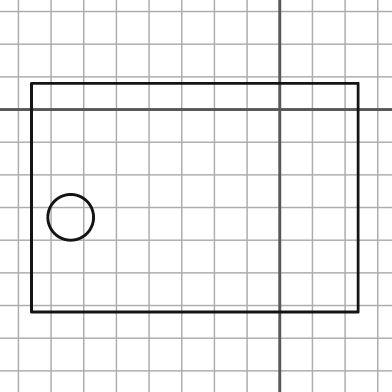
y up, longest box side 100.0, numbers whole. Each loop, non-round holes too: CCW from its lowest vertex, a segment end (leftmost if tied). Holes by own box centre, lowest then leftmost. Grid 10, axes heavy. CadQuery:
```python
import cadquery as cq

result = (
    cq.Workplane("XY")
    .moveTo(-76.0, -62.0)
    .lineTo(24.0, -62.0)
    .lineTo(24.0, 8.0)
    .lineTo(-76.0, 8.0)
    .close()
    .moveTo(-64.0, -33.0)
    .circle(7.0)
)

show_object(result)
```